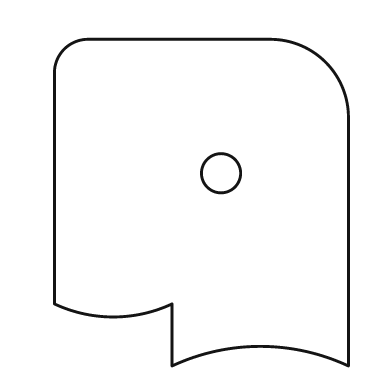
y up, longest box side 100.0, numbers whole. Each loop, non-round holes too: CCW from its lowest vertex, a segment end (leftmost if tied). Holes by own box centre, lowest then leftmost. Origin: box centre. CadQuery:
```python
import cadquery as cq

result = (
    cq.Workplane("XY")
    .moveTo(-9.0, -50.0)
    .threePointArc((18.0, -44.0), (45.0, -50.0))
    .lineTo(45.0, 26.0)
    .threePointArc((38.0, 43.0), (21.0, 50.0))
    .lineTo(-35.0, 50.0)
    .threePointArc((-42.0, 47.0), (-45.0, 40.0))
    .lineTo(-45.0, -31.0)
    .threePointArc((-27.0, -35.0), (-9.0, -31.0))
    .close()
    .moveTo(6.0, 9.0)
    .circle(6.0)
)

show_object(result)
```